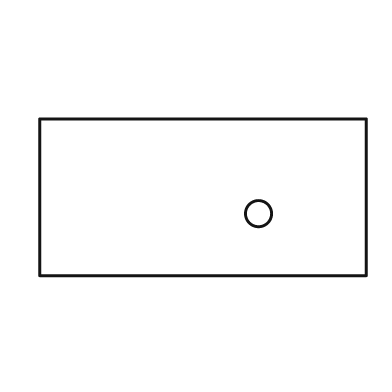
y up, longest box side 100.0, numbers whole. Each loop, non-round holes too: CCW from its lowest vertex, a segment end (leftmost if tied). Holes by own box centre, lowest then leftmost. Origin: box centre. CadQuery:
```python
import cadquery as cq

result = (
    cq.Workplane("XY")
    .moveTo(-50.0, -24.0)
    .lineTo(50.0, -24.0)
    .lineTo(50.0, 24.0)
    .lineTo(-50.0, 24.0)
    .close()
    .moveTo(17.0, -5.0)
    .circle(4.0)
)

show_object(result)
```